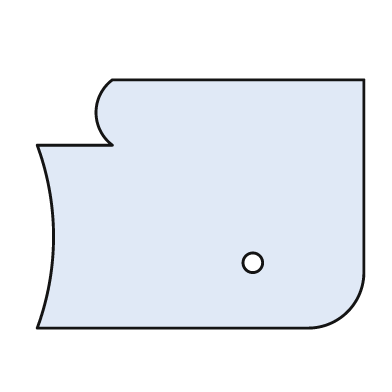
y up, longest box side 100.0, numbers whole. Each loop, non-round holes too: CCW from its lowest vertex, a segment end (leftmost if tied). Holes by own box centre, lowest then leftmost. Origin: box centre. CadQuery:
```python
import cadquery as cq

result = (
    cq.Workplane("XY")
    .moveTo(-50.0, -38.0)
    .lineTo(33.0, -38.0)
    .threePointArc((45.0, -33.0), (50.0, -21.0))
    .lineTo(50.0, 38.0)
    .lineTo(-27.0, 38.0)
    .threePointArc((-32.0, 28.0), (-27.0, 18.0))
    .lineTo(-50.0, 18.0)
    .threePointArc((-45.0, -10.0), (-50.0, -38.0))
    .close()
    .moveTo(16.0, -18.0)
    .circle(3.0)
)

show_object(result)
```